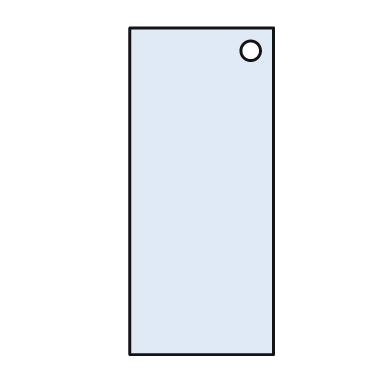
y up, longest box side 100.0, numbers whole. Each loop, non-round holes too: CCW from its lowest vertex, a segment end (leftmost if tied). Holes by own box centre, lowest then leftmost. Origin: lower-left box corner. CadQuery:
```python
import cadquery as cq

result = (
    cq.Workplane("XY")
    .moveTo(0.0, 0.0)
    .lineTo(44.0, 0.0)
    .lineTo(44.0, 100.0)
    .lineTo(0.0, 100.0)
    .close()
    .moveTo(37.0, 93.0)
    .circle(3.0)
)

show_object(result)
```